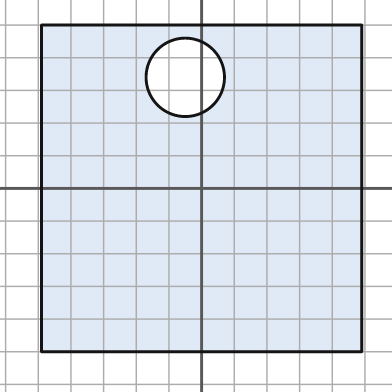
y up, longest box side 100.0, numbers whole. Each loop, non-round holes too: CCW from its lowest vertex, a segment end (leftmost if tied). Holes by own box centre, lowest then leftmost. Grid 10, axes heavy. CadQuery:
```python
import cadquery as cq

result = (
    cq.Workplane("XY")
    .moveTo(-49.0, -50.0)
    .lineTo(49.0, -50.0)
    .lineTo(49.0, 50.0)
    .lineTo(-49.0, 50.0)
    .close()
    .moveTo(-5.0, 34.0)
    .circle(12.0)
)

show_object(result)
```